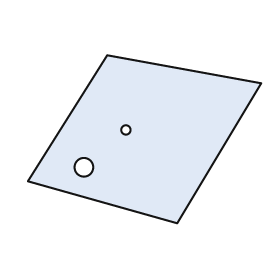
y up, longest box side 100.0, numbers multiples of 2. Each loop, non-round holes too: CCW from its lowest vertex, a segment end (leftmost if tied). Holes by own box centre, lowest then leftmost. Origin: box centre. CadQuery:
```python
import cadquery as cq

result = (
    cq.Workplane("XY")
    .moveTo(14.0, -36.0)
    .lineTo(50.0, 24.0)
    .lineTo(-16.0, 36.0)
    .lineTo(-50.0, -18.0)
    .close()
    .moveTo(-26.0, -12.0)
    .circle(4.0)
    .moveTo(-8.0, 4.0)
    .circle(2.0)
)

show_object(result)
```